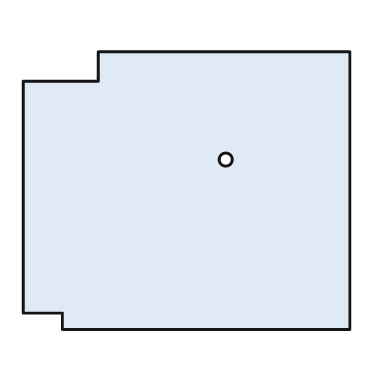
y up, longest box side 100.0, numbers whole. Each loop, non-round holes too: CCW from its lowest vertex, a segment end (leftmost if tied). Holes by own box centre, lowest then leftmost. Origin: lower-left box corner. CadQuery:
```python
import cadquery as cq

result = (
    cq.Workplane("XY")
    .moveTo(12.0, 0.0)
    .lineTo(100.0, 0.0)
    .lineTo(100.0, 85.0)
    .lineTo(23.0, 85.0)
    .lineTo(23.0, 76.0)
    .lineTo(0.0, 76.0)
    .lineTo(0.0, 5.0)
    .lineTo(12.0, 5.0)
    .close()
    .moveTo(62.0, 52.0)
    .circle(2.0)
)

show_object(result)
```